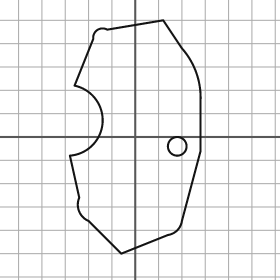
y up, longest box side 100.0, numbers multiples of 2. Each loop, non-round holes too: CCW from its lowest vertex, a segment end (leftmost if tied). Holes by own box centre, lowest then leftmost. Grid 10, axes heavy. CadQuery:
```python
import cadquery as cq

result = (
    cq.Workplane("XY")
    .moveTo(-6.0, -50.0)
    .lineTo(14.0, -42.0)
    .threePointArc((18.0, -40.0), (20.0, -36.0))
    .lineTo(28.0, -6.0)
    .lineTo(28.0, 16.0)
    .threePointArc((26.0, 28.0), (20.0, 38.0))
    .lineTo(12.0, 50.0)
    .lineTo(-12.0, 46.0)
    .threePointArc((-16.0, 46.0), (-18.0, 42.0))
    .lineTo(-26.0, 22.0)
    .threePointArc((-14.0, 6.0), (-28.0, -8.0))
    .lineTo(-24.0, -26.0)
    .threePointArc((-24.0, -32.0), (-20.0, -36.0))
    .close()
    .moveTo(18.0, -4.0)
    .circle(4.0)
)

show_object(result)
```